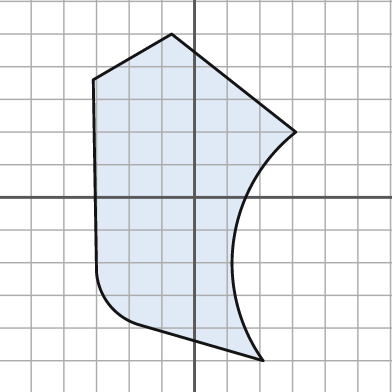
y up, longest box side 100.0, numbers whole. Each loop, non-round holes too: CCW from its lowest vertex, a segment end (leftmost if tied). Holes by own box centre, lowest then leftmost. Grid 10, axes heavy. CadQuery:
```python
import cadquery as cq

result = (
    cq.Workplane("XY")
    .moveTo(21.0, -50.0)
    .threePointArc((12.0, -13.0), (31.0, 20.0))
    .lineTo(-7.0, 50.0)
    .lineTo(-31.0, 36.0)
    .lineTo(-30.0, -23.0)
    .threePointArc((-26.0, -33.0), (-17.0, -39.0))
    .close()
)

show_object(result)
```